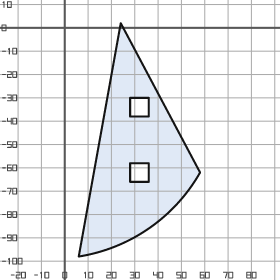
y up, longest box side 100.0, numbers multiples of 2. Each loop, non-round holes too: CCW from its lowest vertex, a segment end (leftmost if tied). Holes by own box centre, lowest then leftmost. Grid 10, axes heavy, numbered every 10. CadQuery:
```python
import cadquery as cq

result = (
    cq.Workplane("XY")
    .moveTo(6.0, -98.0)
    .threePointArc((36.0, -86.0), (58.0, -62.0))
    .lineTo(24.0, 2.0)
    .close()
    .moveTo(28.0, -66.0)
    .lineTo(36.0, -66.0)
    .lineTo(36.0, -58.0)
    .lineTo(28.0, -58.0)
    .close()
    .moveTo(28.0, -38.0)
    .lineTo(36.0, -38.0)
    .lineTo(36.0, -30.0)
    .lineTo(28.0, -30.0)
    .close()
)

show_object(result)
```